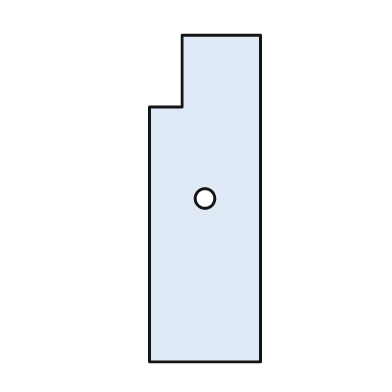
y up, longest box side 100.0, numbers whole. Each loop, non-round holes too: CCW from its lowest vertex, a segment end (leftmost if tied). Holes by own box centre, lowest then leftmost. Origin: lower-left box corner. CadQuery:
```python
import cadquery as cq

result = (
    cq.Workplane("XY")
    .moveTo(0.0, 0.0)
    .lineTo(34.0, 0.0)
    .lineTo(34.0, 100.0)
    .lineTo(10.0, 100.0)
    .lineTo(10.0, 78.0)
    .lineTo(0.0, 78.0)
    .close()
    .moveTo(17.0, 50.0)
    .circle(3.0)
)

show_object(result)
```